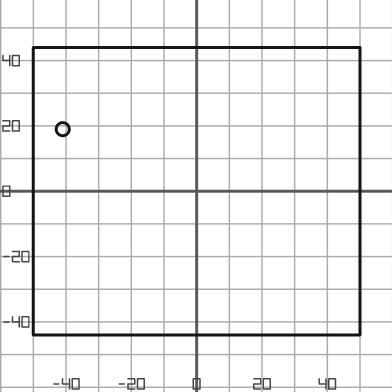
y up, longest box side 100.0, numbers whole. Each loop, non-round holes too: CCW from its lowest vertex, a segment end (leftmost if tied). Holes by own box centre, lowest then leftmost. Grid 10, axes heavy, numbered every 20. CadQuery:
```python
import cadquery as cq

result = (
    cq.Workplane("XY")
    .moveTo(-50.0, -44.0)
    .lineTo(50.0, -44.0)
    .lineTo(50.0, 44.0)
    .lineTo(-50.0, 44.0)
    .close()
    .moveTo(-41.0, 19.0)
    .circle(2.0)
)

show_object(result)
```